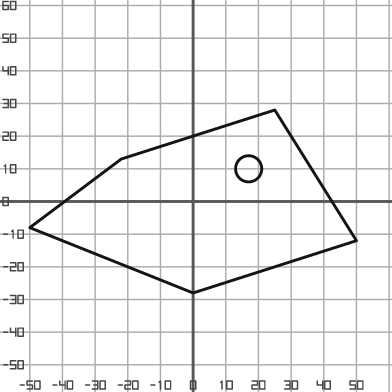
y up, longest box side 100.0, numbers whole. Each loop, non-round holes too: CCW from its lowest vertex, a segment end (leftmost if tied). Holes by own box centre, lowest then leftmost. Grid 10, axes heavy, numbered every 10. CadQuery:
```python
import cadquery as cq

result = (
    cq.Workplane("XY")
    .moveTo(0.0, -28.0)
    .lineTo(50.0, -12.0)
    .lineTo(25.0, 28.0)
    .lineTo(-22.0, 13.0)
    .lineTo(-50.0, -8.0)
    .close()
    .moveTo(17.0, 10.0)
    .circle(4.0)
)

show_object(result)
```